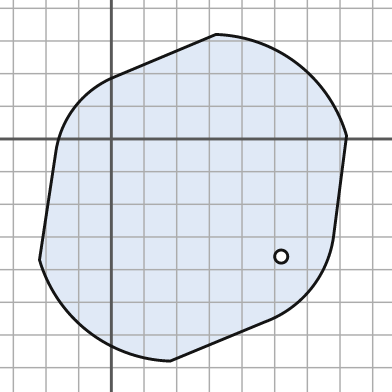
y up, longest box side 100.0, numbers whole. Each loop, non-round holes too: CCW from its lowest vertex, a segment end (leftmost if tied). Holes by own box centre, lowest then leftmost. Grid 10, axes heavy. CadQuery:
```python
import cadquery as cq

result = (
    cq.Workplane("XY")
    .moveTo(18.0, -68.0)
    .lineTo(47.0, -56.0)
    .threePointArc((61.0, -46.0), (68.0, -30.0))
    .lineTo(72.0, 1.0)
    .threePointArc((57.0, 23.0), (32.0, 32.0))
    .lineTo(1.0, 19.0)
    .threePointArc((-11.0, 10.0), (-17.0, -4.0))
    .lineTo(-22.0, -37.0)
    .threePointArc((-7.0, -59.0), (18.0, -68.0))
    .close()
    .moveTo(52.0, -36.0)
    .circle(2.0)
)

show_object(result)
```